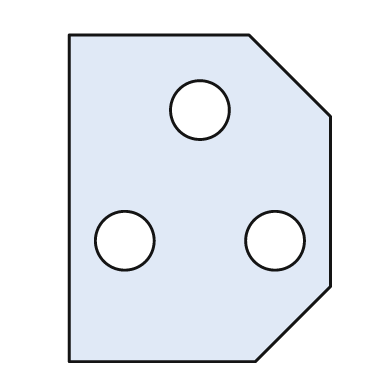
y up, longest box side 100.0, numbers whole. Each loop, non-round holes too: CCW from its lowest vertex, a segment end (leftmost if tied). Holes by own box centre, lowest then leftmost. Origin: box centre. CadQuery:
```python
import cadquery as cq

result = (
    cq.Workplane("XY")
    .moveTo(-40.0, -50.0)
    .lineTo(17.0, -50.0)
    .lineTo(40.0, -27.0)
    .lineTo(40.0, 25.0)
    .lineTo(15.0, 50.0)
    .lineTo(-40.0, 50.0)
    .close()
    .moveTo(-23.0, -13.0)
    .circle(9.0)
    .moveTo(23.0, -13.0)
    .circle(9.0)
    .moveTo(0.0, 27.0)
    .circle(9.0)
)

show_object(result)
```